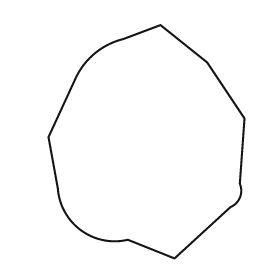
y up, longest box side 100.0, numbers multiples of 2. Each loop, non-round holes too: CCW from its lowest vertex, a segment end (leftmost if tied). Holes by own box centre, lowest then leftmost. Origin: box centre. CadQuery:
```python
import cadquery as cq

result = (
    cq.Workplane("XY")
    .moveTo(12.0, -50.0)
    .lineTo(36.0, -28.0)
    .threePointArc((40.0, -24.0), (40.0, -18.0))
    .lineTo(42.0, 10.0)
    .lineTo(26.0, 34.0)
    .lineTo(6.0, 50.0)
    .lineTo(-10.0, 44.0)
    .threePointArc((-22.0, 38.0), (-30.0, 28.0))
    .lineTo(-42.0, 2.0)
    .lineTo(-38.0, -20.0)
    .threePointArc((-28.0, -38.0), (-8.0, -42.0))
    .close()
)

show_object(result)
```